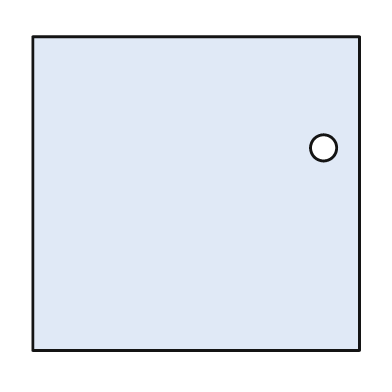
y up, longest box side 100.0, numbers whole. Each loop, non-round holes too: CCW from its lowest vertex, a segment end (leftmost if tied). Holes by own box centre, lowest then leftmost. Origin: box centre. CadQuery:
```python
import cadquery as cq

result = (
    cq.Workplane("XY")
    .moveTo(-50.0, -48.0)
    .lineTo(50.0, -48.0)
    .lineTo(50.0, 48.0)
    .lineTo(-50.0, 48.0)
    .close()
    .moveTo(39.0, 14.0)
    .circle(4.0)
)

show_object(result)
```